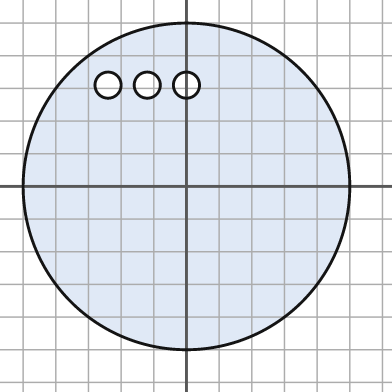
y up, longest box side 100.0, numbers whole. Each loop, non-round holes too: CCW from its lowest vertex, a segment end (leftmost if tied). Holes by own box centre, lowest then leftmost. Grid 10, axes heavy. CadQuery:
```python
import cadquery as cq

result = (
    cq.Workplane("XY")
    .moveTo(0.0, 0.0)
    .circle(50.0)
    .moveTo(-24.0, 31.0)
    .circle(4.0)
    .moveTo(-12.0, 31.0)
    .circle(4.0)
    .moveTo(0.0, 31.0)
    .circle(4.0)
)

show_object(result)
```